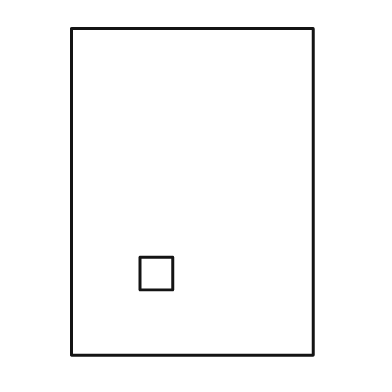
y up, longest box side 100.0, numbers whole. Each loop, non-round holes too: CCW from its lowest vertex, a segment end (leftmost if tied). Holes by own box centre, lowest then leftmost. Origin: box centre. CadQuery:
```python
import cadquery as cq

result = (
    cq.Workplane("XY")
    .moveTo(-37.0, -50.0)
    .lineTo(37.0, -50.0)
    .lineTo(37.0, 50.0)
    .lineTo(-37.0, 50.0)
    .close()
    .moveTo(-16.0, -30.0)
    .lineTo(-6.0, -30.0)
    .lineTo(-6.0, -20.0)
    .lineTo(-16.0, -20.0)
    .close()
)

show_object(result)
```